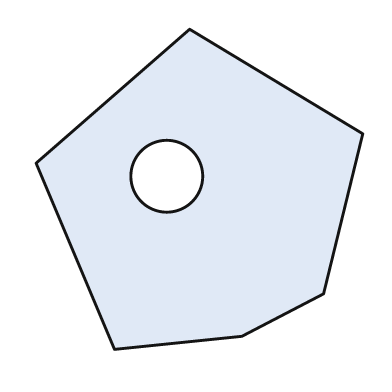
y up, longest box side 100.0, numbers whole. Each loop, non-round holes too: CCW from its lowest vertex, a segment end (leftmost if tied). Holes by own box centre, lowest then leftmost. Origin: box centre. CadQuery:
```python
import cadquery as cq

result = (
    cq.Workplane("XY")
    .moveTo(-26.0, -49.0)
    .lineTo(13.0, -45.0)
    .lineTo(38.0, -32.0)
    .lineTo(50.0, 17.0)
    .lineTo(-3.0, 49.0)
    .lineTo(-50.0, 8.0)
    .close()
    .moveTo(-10.0, 4.0)
    .circle(11.0)
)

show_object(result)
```